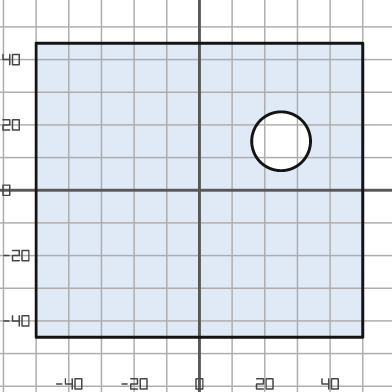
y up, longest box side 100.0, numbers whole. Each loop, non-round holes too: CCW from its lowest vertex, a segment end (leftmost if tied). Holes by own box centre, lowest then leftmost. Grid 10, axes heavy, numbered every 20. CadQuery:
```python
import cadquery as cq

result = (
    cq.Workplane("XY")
    .moveTo(-50.0, -45.0)
    .lineTo(50.0, -45.0)
    .lineTo(50.0, 45.0)
    .lineTo(-50.0, 45.0)
    .close()
    .moveTo(25.0, 15.0)
    .circle(9.0)
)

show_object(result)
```